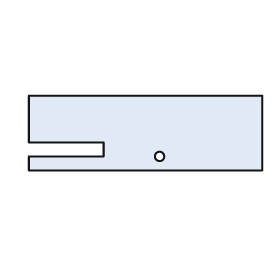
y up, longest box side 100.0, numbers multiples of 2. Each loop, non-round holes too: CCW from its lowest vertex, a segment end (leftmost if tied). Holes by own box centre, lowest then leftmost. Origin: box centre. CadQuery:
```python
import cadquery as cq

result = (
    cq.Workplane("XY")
    .moveTo(-50.0, -16.0)
    .lineTo(50.0, -16.0)
    .lineTo(50.0, 16.0)
    .lineTo(-50.0, 16.0)
    .lineTo(-50.0, -4.0)
    .lineTo(-18.0, -4.0)
    .lineTo(-18.0, -10.0)
    .lineTo(-50.0, -10.0)
    .close()
    .moveTo(6.0, -10.0)
    .circle(2.0)
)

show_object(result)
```